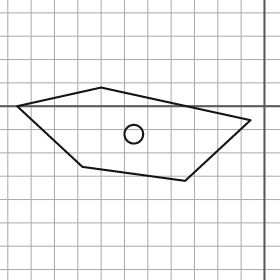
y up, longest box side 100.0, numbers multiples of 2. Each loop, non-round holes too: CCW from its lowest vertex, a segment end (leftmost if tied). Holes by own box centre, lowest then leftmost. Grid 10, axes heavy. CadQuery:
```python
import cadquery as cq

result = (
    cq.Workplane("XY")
    .moveTo(-34.0, -32.0)
    .lineTo(-6.0, -6.0)
    .lineTo(-70.0, 8.0)
    .lineTo(-106.0, 0.0)
    .lineTo(-78.0, -26.0)
    .close()
    .moveTo(-56.0, -12.0)
    .circle(4.0)
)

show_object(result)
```